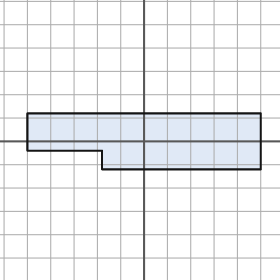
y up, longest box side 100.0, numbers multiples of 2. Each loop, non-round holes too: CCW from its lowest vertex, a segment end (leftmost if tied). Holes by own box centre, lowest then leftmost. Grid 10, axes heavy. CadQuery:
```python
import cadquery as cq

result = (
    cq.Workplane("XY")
    .moveTo(-18.0, -12.0)
    .lineTo(50.0, -12.0)
    .lineTo(50.0, 12.0)
    .lineTo(-50.0, 12.0)
    .lineTo(-50.0, -4.0)
    .lineTo(-18.0, -4.0)
    .close()
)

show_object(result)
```